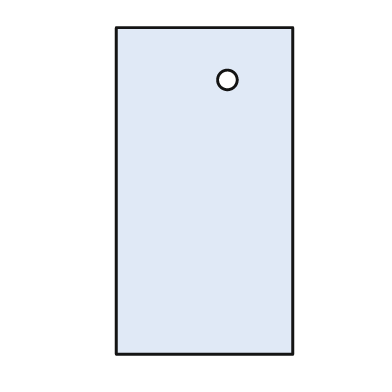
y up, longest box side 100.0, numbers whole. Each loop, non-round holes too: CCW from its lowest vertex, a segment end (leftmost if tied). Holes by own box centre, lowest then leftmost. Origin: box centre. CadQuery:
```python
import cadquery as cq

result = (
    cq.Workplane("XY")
    .moveTo(-27.0, -50.0)
    .lineTo(27.0, -50.0)
    .lineTo(27.0, 50.0)
    .lineTo(-27.0, 50.0)
    .close()
    .moveTo(7.0, 34.0)
    .circle(3.0)
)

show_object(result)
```